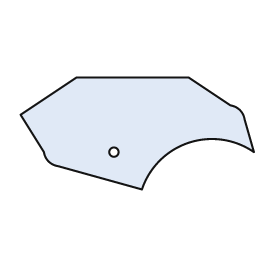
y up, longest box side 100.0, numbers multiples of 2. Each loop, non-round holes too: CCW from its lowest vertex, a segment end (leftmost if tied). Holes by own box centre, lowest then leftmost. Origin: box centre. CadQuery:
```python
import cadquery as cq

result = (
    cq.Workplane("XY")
    .moveTo(2.0, -24.0)
    .threePointArc((22.0, -4.0), (50.0, -8.0))
    .lineTo(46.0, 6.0)
    .threePointArc((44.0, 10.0), (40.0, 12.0))
    .lineTo(22.0, 24.0)
    .lineTo(-26.0, 24.0)
    .lineTo(-50.0, 8.0)
    .lineTo(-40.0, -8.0)
    .threePointArc((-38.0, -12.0), (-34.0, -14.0))
    .close()
    .moveTo(-10.0, -8.0)
    .circle(2.0)
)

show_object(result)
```